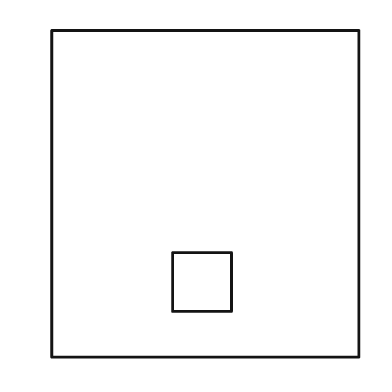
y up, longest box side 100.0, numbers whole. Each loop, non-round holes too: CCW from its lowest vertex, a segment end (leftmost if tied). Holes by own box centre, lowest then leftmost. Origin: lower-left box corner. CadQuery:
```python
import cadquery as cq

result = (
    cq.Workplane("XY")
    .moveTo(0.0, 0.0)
    .lineTo(94.0, 0.0)
    .lineTo(94.0, 100.0)
    .lineTo(0.0, 100.0)
    .close()
    .moveTo(37.0, 14.0)
    .lineTo(55.0, 14.0)
    .lineTo(55.0, 32.0)
    .lineTo(37.0, 32.0)
    .close()
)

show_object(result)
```